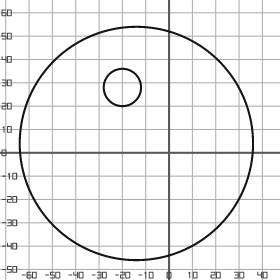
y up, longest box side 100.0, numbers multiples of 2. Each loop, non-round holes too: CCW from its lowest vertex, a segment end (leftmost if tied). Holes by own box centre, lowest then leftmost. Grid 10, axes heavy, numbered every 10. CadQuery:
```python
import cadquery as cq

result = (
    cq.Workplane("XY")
    .moveTo(-14.0, 4.0)
    .circle(50.0)
    .moveTo(-20.0, 28.0)
    .circle(8.0)
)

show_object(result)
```